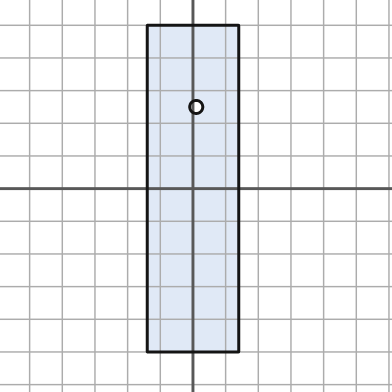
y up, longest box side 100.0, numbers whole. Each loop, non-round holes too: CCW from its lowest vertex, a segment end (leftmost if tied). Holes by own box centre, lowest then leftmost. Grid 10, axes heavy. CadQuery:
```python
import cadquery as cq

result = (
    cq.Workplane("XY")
    .moveTo(-14.0, -50.0)
    .lineTo(14.0, -50.0)
    .lineTo(14.0, 50.0)
    .lineTo(-14.0, 50.0)
    .close()
    .moveTo(1.0, 25.0)
    .circle(2.0)
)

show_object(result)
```